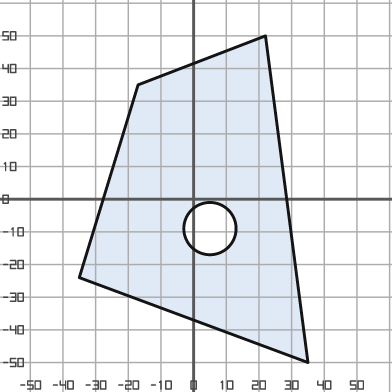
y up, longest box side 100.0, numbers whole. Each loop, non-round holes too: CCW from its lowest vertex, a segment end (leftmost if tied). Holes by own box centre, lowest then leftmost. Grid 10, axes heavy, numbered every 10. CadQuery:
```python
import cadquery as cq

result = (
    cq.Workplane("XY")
    .moveTo(35.0, -50.0)
    .lineTo(22.0, 50.0)
    .lineTo(-17.0, 35.0)
    .lineTo(-35.0, -24.0)
    .close()
    .moveTo(5.0, -9.0)
    .circle(8.0)
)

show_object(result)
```